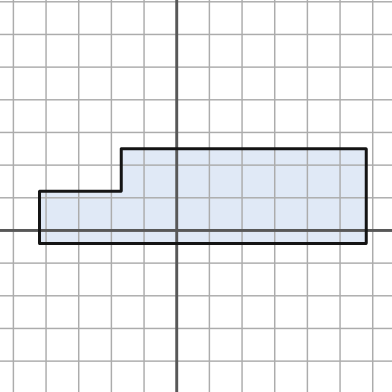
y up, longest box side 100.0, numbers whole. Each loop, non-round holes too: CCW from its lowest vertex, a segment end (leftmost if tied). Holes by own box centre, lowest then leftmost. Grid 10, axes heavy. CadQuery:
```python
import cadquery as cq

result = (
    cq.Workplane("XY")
    .moveTo(-42.0, -4.0)
    .lineTo(58.0, -4.0)
    .lineTo(58.0, 25.0)
    .lineTo(-17.0, 25.0)
    .lineTo(-17.0, 12.0)
    .lineTo(-42.0, 12.0)
    .close()
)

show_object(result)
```